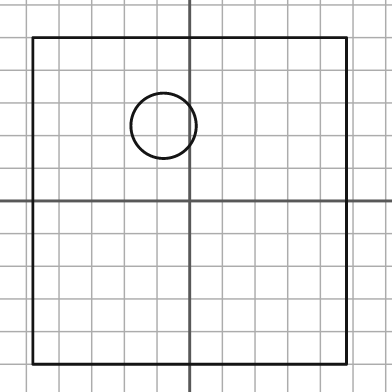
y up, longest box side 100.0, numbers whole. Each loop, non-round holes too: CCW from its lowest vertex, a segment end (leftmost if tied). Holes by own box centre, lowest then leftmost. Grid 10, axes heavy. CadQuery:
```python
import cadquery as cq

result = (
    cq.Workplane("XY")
    .moveTo(-48.0, -50.0)
    .lineTo(48.0, -50.0)
    .lineTo(48.0, 50.0)
    .lineTo(-48.0, 50.0)
    .close()
    .moveTo(-8.0, 23.0)
    .circle(10.0)
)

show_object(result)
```